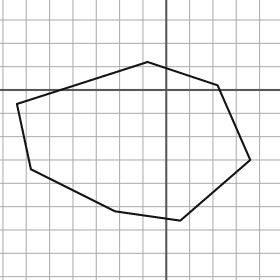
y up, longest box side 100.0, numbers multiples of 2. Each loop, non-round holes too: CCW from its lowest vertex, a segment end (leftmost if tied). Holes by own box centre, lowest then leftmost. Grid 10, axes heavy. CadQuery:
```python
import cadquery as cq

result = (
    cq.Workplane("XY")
    .moveTo(6.0, -56.0)
    .lineTo(36.0, -30.0)
    .lineTo(22.0, 2.0)
    .lineTo(-8.0, 12.0)
    .lineTo(-64.0, -6.0)
    .lineTo(-58.0, -34.0)
    .lineTo(-22.0, -52.0)
    .close()
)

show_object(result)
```